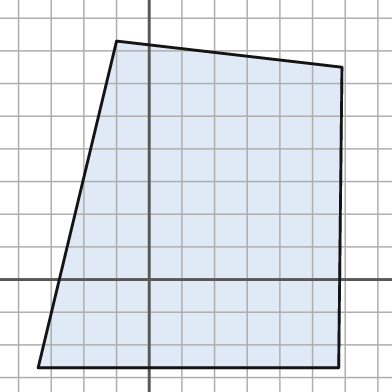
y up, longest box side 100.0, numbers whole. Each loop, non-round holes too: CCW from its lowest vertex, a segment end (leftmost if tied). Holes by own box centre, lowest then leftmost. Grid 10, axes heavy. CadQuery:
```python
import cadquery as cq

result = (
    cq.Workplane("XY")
    .moveTo(-34.0, -27.0)
    .lineTo(58.0, -27.0)
    .lineTo(59.0, 65.0)
    .lineTo(-10.0, 73.0)
    .close()
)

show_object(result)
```